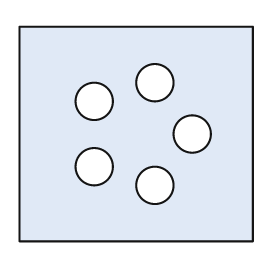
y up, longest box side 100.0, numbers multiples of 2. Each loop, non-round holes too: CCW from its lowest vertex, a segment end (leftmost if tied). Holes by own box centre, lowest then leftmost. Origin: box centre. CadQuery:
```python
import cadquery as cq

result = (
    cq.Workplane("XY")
    .moveTo(-50.0, -46.0)
    .lineTo(50.0, -46.0)
    .lineTo(50.0, 46.0)
    .lineTo(-50.0, 46.0)
    .close()
    .moveTo(8.0, -22.0)
    .circle(8.0)
    .moveTo(-18.0, -14.0)
    .circle(8.0)
    .moveTo(24.0, 0.0)
    .circle(8.0)
    .moveTo(-18.0, 14.0)
    .circle(8.0)
    .moveTo(8.0, 22.0)
    .circle(8.0)
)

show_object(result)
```